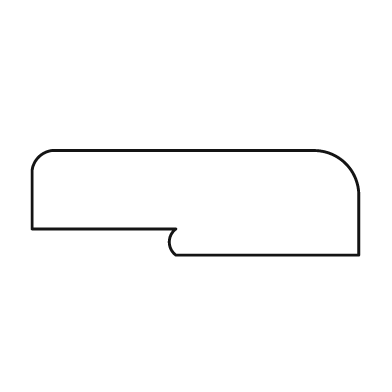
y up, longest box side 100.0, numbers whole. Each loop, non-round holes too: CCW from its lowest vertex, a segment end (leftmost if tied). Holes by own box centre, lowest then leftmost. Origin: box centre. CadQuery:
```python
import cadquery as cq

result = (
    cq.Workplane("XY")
    .moveTo(-6.0, -16.0)
    .lineTo(50.0, -16.0)
    .lineTo(50.0, 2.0)
    .threePointArc((46.0, 12.0), (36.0, 16.0))
    .lineTo(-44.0, 16.0)
    .threePointArc((-48.0, 14.0), (-50.0, 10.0))
    .lineTo(-50.0, -8.0)
    .lineTo(-6.0, -8.0)
    .threePointArc((-8.0, -12.0), (-6.0, -16.0))
    .close()
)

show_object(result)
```